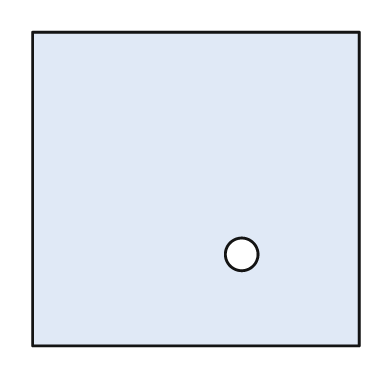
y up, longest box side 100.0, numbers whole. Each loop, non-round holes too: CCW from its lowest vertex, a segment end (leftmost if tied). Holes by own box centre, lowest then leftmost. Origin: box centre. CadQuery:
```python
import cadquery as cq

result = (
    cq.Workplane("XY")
    .moveTo(-50.0, -48.0)
    .lineTo(50.0, -48.0)
    .lineTo(50.0, 48.0)
    .lineTo(-50.0, 48.0)
    .close()
    .moveTo(14.0, -20.0)
    .circle(5.0)
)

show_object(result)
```